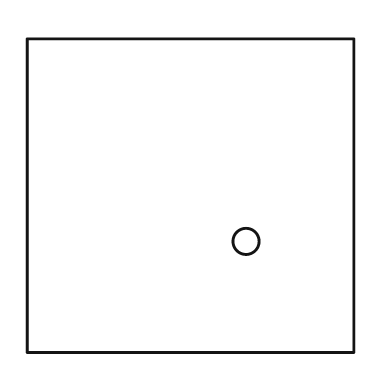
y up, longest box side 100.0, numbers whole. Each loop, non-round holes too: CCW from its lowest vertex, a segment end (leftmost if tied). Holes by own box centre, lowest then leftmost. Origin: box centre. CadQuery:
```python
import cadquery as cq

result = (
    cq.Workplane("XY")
    .moveTo(-50.0, -48.0)
    .lineTo(50.0, -48.0)
    .lineTo(50.0, 48.0)
    .lineTo(-50.0, 48.0)
    .close()
    .moveTo(17.0, -14.0)
    .circle(4.0)
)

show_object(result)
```